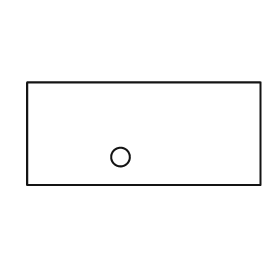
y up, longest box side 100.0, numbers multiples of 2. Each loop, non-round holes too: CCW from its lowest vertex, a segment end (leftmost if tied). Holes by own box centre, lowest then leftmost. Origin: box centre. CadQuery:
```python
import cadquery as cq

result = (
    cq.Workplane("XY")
    .moveTo(-50.0, -22.0)
    .lineTo(50.0, -22.0)
    .lineTo(50.0, 22.0)
    .lineTo(-50.0, 22.0)
    .close()
    .moveTo(-10.0, -10.0)
    .circle(4.0)
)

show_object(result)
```